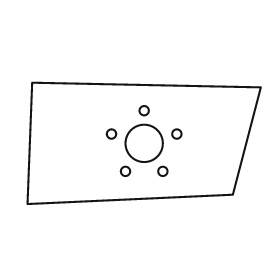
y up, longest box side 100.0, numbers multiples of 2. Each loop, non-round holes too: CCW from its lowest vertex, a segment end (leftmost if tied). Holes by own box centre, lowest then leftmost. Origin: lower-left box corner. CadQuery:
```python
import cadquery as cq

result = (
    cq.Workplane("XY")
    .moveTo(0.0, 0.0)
    .lineTo(88.0, 4.0)
    .lineTo(100.0, 50.0)
    .lineTo(2.0, 52.0)
    .close()
    .moveTo(42.0, 14.0)
    .circle(2.0)
    .moveTo(58.0, 14.0)
    .circle(2.0)
    .moveTo(50.0, 26.0)
    .circle(8.0)
    .moveTo(36.0, 30.0)
    .circle(2.0)
    .moveTo(64.0, 30.0)
    .circle(2.0)
    .moveTo(50.0, 40.0)
    .circle(2.0)
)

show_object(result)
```